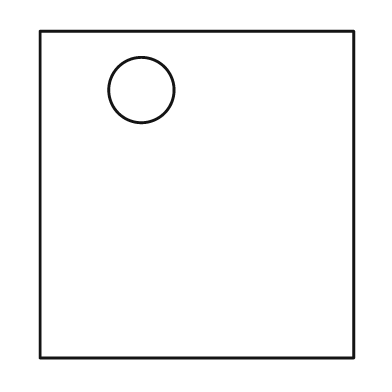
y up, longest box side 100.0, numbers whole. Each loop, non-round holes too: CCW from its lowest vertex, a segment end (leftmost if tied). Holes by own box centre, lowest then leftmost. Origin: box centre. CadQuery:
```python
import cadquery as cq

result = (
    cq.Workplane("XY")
    .moveTo(-48.0, -50.0)
    .lineTo(48.0, -50.0)
    .lineTo(48.0, 50.0)
    .lineTo(-48.0, 50.0)
    .close()
    .moveTo(-17.0, 32.0)
    .circle(10.0)
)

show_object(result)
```